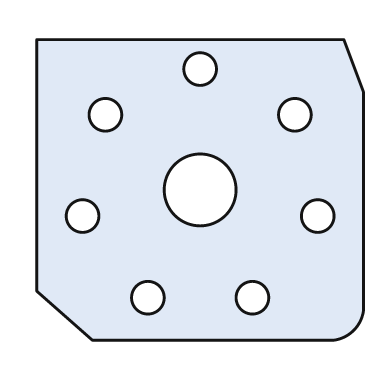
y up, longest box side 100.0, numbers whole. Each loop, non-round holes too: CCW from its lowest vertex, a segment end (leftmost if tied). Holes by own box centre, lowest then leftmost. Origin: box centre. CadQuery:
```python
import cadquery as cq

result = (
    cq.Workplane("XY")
    .moveTo(-33.0, -46.0)
    .lineTo(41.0, -46.0)
    .threePointArc((47.0, -43.0), (50.0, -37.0))
    .lineTo(50.0, 30.0)
    .lineTo(44.0, 46.0)
    .lineTo(-50.0, 46.0)
    .lineTo(-50.0, -31.0)
    .close()
    .moveTo(-16.0, -33.0)
    .circle(5.0)
    .moveTo(16.0, -33.0)
    .circle(5.0)
    .moveTo(-36.0, -8.0)
    .circle(5.0)
    .moveTo(36.0, -8.0)
    .circle(5.0)
    .moveTo(0.0, 0.0)
    .circle(11.0)
    .moveTo(-29.0, 23.0)
    .circle(5.0)
    .moveTo(29.0, 23.0)
    .circle(5.0)
    .moveTo(0.0, 37.0)
    .circle(5.0)
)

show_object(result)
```